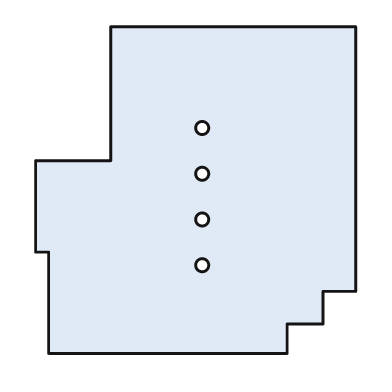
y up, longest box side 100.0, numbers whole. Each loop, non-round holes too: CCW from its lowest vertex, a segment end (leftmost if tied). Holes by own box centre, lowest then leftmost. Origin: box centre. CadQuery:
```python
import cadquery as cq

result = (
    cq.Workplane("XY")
    .moveTo(-45.0, -50.0)
    .lineTo(28.0, -50.0)
    .lineTo(28.0, -41.0)
    .lineTo(39.0, -41.0)
    .lineTo(39.0, -31.0)
    .lineTo(49.0, -31.0)
    .lineTo(49.0, 50.0)
    .lineTo(-26.0, 50.0)
    .lineTo(-26.0, 9.0)
    .lineTo(-49.0, 9.0)
    .lineTo(-49.0, -19.0)
    .lineTo(-45.0, -19.0)
    .close()
    .moveTo(2.0, -23.0)
    .circle(2.0)
    .moveTo(2.0, -9.0)
    .circle(2.0)
    .moveTo(2.0, 5.0)
    .circle(2.0)
    .moveTo(2.0, 19.0)
    .circle(2.0)
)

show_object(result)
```